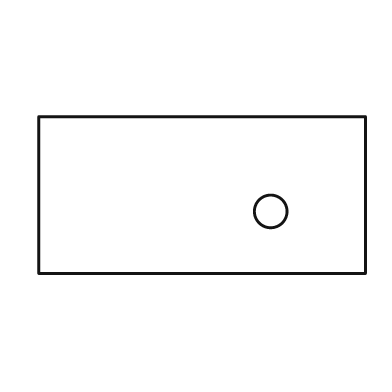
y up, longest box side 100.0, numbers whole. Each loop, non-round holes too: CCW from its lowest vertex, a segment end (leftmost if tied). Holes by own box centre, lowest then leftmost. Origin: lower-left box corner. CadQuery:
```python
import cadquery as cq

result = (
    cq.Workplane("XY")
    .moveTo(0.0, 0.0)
    .lineTo(100.0, 0.0)
    .lineTo(100.0, 48.0)
    .lineTo(0.0, 48.0)
    .close()
    .moveTo(71.0, 19.0)
    .circle(5.0)
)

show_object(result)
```